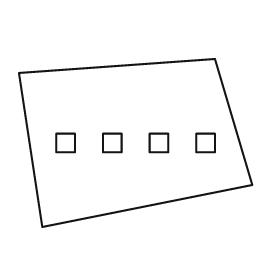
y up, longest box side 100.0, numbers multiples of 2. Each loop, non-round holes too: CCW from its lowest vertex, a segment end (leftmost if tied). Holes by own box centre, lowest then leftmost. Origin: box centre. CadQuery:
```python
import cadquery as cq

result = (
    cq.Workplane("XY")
    .moveTo(-40.0, -36.0)
    .lineTo(50.0, -18.0)
    .lineTo(34.0, 36.0)
    .lineTo(-50.0, 30.0)
    .close()
    .moveTo(-34.0, -4.0)
    .lineTo(-26.0, -4.0)
    .lineTo(-26.0, 4.0)
    .lineTo(-34.0, 4.0)
    .close()
    .moveTo(-14.0, -4.0)
    .lineTo(-6.0, -4.0)
    .lineTo(-6.0, 4.0)
    .lineTo(-14.0, 4.0)
    .close()
    .moveTo(6.0, -4.0)
    .lineTo(14.0, -4.0)
    .lineTo(14.0, 4.0)
    .lineTo(6.0, 4.0)
    .close()
    .moveTo(26.0, -4.0)
    .lineTo(34.0, -4.0)
    .lineTo(34.0, 4.0)
    .lineTo(26.0, 4.0)
    .close()
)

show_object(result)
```